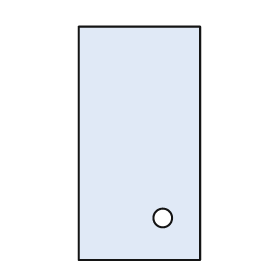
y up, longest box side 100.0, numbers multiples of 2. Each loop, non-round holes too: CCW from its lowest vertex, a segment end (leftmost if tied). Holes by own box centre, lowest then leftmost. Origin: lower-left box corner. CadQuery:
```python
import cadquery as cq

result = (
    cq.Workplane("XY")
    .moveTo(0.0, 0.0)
    .lineTo(52.0, 0.0)
    .lineTo(52.0, 100.0)
    .lineTo(0.0, 100.0)
    .close()
    .moveTo(36.0, 18.0)
    .circle(4.0)
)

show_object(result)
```